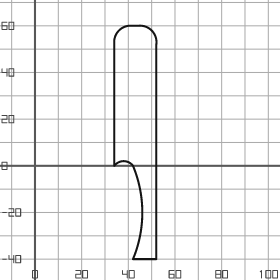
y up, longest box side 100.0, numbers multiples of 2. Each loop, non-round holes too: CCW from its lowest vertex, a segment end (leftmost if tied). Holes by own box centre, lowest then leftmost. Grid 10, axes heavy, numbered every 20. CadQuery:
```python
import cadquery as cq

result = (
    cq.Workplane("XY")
    .moveTo(42.0, -40.0)
    .lineTo(52.0, -40.0)
    .lineTo(52.0, 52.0)
    .threePointArc((50.0, 58.0), (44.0, 60.0))
    .lineTo(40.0, 60.0)
    .threePointArc((36.0, 58.0), (34.0, 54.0))
    .lineTo(34.0, 0.0)
    .threePointArc((38.0, 2.0), (42.0, 0.0))
    .threePointArc((46.0, -20.0), (42.0, -40.0))
    .close()
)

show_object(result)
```